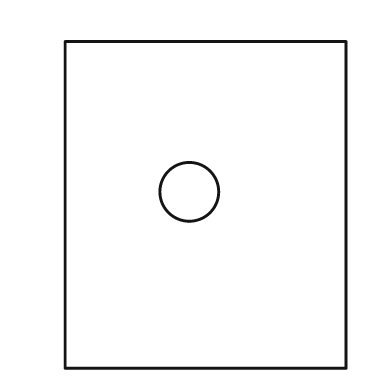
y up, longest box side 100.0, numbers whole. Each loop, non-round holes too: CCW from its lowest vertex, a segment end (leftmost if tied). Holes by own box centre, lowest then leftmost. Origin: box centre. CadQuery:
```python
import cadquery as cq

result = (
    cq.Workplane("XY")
    .moveTo(-43.0, -50.0)
    .lineTo(43.0, -50.0)
    .lineTo(43.0, 50.0)
    .lineTo(-43.0, 50.0)
    .close()
    .moveTo(-5.0, 4.0)
    .circle(9.0)
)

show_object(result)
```